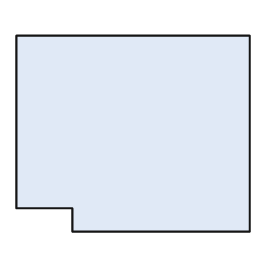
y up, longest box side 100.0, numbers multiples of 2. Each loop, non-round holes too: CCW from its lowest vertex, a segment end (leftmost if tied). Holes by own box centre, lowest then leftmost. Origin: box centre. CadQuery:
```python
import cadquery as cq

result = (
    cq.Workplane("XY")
    .moveTo(-26.0, -42.0)
    .lineTo(50.0, -42.0)
    .lineTo(50.0, 42.0)
    .lineTo(-50.0, 42.0)
    .lineTo(-50.0, -32.0)
    .lineTo(-26.0, -32.0)
    .close()
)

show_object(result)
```